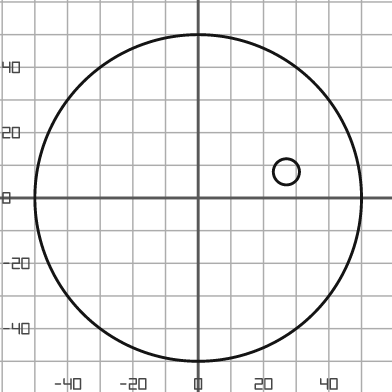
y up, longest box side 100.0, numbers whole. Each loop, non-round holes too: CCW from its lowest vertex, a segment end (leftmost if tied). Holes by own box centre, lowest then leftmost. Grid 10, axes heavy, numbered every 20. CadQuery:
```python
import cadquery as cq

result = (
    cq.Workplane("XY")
    .moveTo(0.0, 0.0)
    .circle(50.0)
    .moveTo(27.0, 8.0)
    .circle(4.0)
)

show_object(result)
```